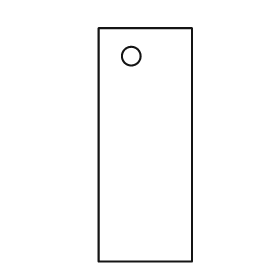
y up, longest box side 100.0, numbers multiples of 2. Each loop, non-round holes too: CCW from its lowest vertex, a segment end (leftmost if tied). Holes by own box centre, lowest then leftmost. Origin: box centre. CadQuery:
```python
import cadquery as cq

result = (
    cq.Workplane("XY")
    .moveTo(-20.0, -50.0)
    .lineTo(20.0, -50.0)
    .lineTo(20.0, 50.0)
    .lineTo(-20.0, 50.0)
    .close()
    .moveTo(-6.0, 38.0)
    .circle(4.0)
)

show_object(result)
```